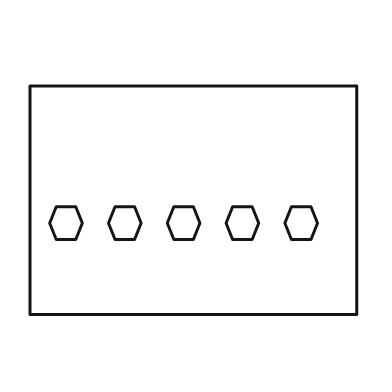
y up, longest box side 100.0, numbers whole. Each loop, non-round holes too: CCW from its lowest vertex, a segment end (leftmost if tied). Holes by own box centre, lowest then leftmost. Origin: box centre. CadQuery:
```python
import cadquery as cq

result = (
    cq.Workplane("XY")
    .moveTo(-50.0, -35.0)
    .lineTo(50.0, -35.0)
    .lineTo(50.0, 35.0)
    .lineTo(-50.0, 35.0)
    .close()
    .moveTo(-42.0, -12.0)
    .lineTo(-36.0, -12.0)
    .lineTo(-34.0, -7.0)
    .lineTo(-36.0, -2.0)
    .lineTo(-42.0, -2.0)
    .lineTo(-44.0, -7.0)
    .close()
    .moveTo(-24.0, -12.0)
    .lineTo(-18.0, -12.0)
    .lineTo(-16.0, -7.0)
    .lineTo(-18.0, -2.0)
    .lineTo(-24.0, -2.0)
    .lineTo(-26.0, -7.0)
    .close()
    .moveTo(-6.0, -12.0)
    .lineTo(0.0, -12.0)
    .lineTo(2.0, -7.0)
    .lineTo(0.0, -2.0)
    .lineTo(-6.0, -2.0)
    .lineTo(-8.0, -7.0)
    .close()
    .moveTo(12.0, -12.0)
    .lineTo(18.0, -12.0)
    .lineTo(20.0, -7.0)
    .lineTo(18.0, -2.0)
    .lineTo(12.0, -2.0)
    .lineTo(10.0, -7.0)
    .close()
    .moveTo(30.0, -12.0)
    .lineTo(36.0, -12.0)
    .lineTo(38.0, -7.0)
    .lineTo(36.0, -2.0)
    .lineTo(30.0, -2.0)
    .lineTo(28.0, -7.0)
    .close()
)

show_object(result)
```